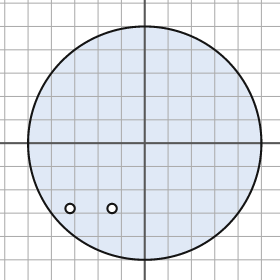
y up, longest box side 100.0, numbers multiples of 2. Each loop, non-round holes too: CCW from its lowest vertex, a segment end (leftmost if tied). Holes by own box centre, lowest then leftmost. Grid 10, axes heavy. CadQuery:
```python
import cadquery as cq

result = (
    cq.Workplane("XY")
    .moveTo(0.0, 0.0)
    .circle(50.0)
    .moveTo(-32.0, -28.0)
    .circle(2.0)
    .moveTo(-14.0, -28.0)
    .circle(2.0)
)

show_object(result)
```